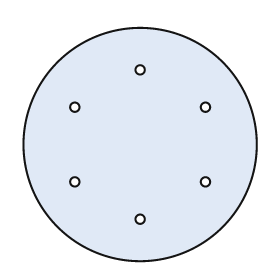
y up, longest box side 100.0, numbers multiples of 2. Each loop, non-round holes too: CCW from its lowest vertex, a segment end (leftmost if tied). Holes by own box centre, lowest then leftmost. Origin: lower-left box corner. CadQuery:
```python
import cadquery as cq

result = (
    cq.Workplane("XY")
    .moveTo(50.0, 50.0)
    .circle(50.0)
    .moveTo(50.0, 18.0)
    .circle(2.0)
    .moveTo(22.0, 34.0)
    .circle(2.0)
    .moveTo(78.0, 34.0)
    .circle(2.0)
    .moveTo(22.0, 66.0)
    .circle(2.0)
    .moveTo(78.0, 66.0)
    .circle(2.0)
    .moveTo(50.0, 82.0)
    .circle(2.0)
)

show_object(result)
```